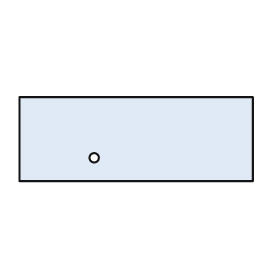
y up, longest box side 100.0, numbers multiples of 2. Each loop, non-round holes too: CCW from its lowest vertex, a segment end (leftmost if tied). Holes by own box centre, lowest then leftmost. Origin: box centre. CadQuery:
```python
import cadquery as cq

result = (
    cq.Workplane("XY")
    .moveTo(-50.0, -18.0)
    .lineTo(50.0, -18.0)
    .lineTo(50.0, 18.0)
    .lineTo(-50.0, 18.0)
    .close()
    .moveTo(-18.0, -8.0)
    .circle(2.0)
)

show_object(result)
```